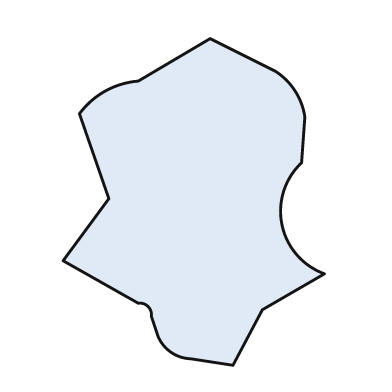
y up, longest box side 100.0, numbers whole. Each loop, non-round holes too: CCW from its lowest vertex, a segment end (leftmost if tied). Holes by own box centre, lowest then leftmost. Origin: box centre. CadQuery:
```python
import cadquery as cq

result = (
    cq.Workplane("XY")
    .moveTo(12.0, -50.0)
    .lineTo(21.0, -33.0)
    .lineTo(40.0, -22.0)
    .threePointArc((27.0, -7.0), (33.0, 12.0))
    .lineTo(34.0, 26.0)
    .threePointArc((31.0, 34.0), (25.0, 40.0))
    .lineTo(5.0, 50.0)
    .lineTo(-17.0, 37.0)
    .threePointArc((-27.0, 34.0), (-35.0, 27.0))
    .lineTo(-26.0, 1.0)
    .lineTo(-40.0, -18.0)
    .lineTo(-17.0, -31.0)
    .threePointArc((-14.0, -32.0), (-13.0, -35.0))
    .lineTo(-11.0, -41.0)
    .threePointArc((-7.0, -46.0), (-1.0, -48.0))
    .close()
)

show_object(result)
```